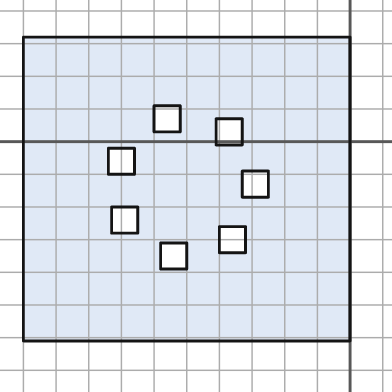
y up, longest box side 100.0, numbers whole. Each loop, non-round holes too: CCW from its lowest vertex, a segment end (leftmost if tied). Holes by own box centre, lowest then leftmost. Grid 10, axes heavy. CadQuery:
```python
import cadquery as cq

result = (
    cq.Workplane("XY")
    .moveTo(-100.0, -61.0)
    .lineTo(0.0, -61.0)
    .lineTo(0.0, 32.0)
    .lineTo(-100.0, 32.0)
    .close()
    .moveTo(-58.0, -39.0)
    .lineTo(-50.0, -39.0)
    .lineTo(-50.0, -31.0)
    .lineTo(-58.0, -31.0)
    .close()
    .moveTo(-40.0, -34.0)
    .lineTo(-32.0, -34.0)
    .lineTo(-32.0, -26.0)
    .lineTo(-40.0, -26.0)
    .close()
    .moveTo(-73.0, -28.0)
    .lineTo(-65.0, -28.0)
    .lineTo(-65.0, -20.0)
    .lineTo(-73.0, -20.0)
    .close()
    .moveTo(-33.0, -17.0)
    .lineTo(-25.0, -17.0)
    .lineTo(-25.0, -9.0)
    .lineTo(-33.0, -9.0)
    .close()
    .moveTo(-74.0, -10.0)
    .lineTo(-66.0, -10.0)
    .lineTo(-66.0, -2.0)
    .lineTo(-74.0, -2.0)
    .close()
    .moveTo(-41.0, -1.0)
    .lineTo(-33.0, -1.0)
    .lineTo(-33.0, 7.0)
    .lineTo(-41.0, 7.0)
    .close()
    .moveTo(-60.0, 3.0)
    .lineTo(-52.0, 3.0)
    .lineTo(-52.0, 11.0)
    .lineTo(-60.0, 11.0)
    .close()
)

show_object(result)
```